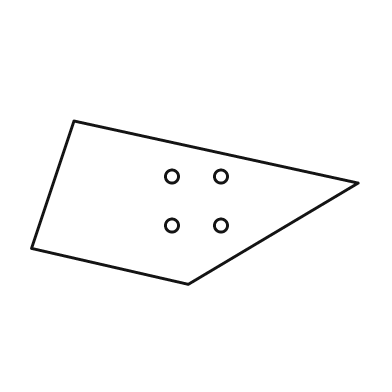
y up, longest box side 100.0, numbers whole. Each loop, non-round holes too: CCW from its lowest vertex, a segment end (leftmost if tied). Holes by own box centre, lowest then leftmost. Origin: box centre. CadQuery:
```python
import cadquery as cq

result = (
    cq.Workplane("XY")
    .moveTo(-2.0, -25.0)
    .lineTo(50.0, 6.0)
    .lineTo(-37.0, 25.0)
    .lineTo(-50.0, -14.0)
    .close()
    .moveTo(-7.0, -7.0)
    .circle(2.0)
    .moveTo(8.0, -7.0)
    .circle(2.0)
    .moveTo(-7.0, 8.0)
    .circle(2.0)
    .moveTo(8.0, 8.0)
    .circle(2.0)
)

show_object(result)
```